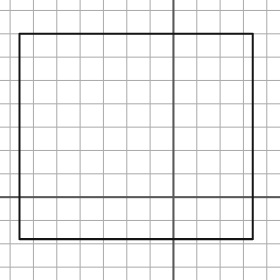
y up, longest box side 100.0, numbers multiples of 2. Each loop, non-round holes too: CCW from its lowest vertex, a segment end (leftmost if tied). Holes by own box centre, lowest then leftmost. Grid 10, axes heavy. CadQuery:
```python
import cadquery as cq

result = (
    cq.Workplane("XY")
    .moveTo(-66.0, -18.0)
    .lineTo(34.0, -18.0)
    .lineTo(34.0, 70.0)
    .lineTo(-66.0, 70.0)
    .close()
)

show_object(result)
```